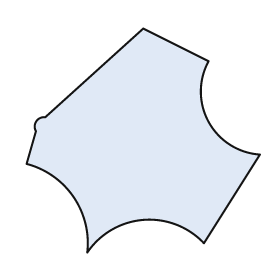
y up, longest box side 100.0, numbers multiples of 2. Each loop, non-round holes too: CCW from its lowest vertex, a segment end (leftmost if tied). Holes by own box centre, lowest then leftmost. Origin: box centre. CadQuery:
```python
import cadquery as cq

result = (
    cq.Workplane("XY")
    .moveTo(-24.0, -48.0)
    .threePointArc((0.0, -34.0), (26.0, -44.0))
    .lineTo(50.0, -6.0)
    .threePointArc((28.0, 8.0), (28.0, 34.0))
    .lineTo(0.0, 48.0)
    .lineTo(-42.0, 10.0)
    .threePointArc((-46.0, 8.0), (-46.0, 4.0))
    .lineTo(-50.0, -10.0)
    .threePointArc((-30.0, -24.0), (-24.0, -48.0))
    .close()
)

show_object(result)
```